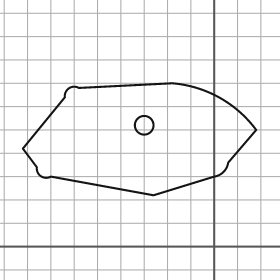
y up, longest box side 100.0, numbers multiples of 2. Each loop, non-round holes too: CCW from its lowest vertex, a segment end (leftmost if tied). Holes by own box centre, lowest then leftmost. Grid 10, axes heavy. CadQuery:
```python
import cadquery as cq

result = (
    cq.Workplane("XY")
    .moveTo(-26.0, 22.0)
    .lineTo(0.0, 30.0)
    .threePointArc((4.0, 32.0), (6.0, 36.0))
    .lineTo(18.0, 50.0)
    .threePointArc((2.0, 64.0), (-18.0, 70.0))
    .lineTo(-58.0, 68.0)
    .threePointArc((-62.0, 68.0), (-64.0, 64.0))
    .lineTo(-82.0, 42.0)
    .lineTo(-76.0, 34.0)
    .threePointArc((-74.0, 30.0), (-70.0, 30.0))
    .close()
    .moveTo(-30.0, 52.0)
    .circle(4.0)
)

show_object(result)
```